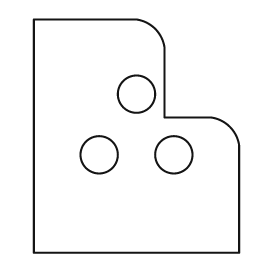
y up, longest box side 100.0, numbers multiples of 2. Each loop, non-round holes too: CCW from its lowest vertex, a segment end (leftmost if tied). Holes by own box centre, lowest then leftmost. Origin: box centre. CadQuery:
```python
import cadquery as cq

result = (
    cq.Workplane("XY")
    .moveTo(-44.0, -50.0)
    .lineTo(44.0, -50.0)
    .lineTo(44.0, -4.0)
    .threePointArc((40.0, 4.0), (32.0, 8.0))
    .lineTo(12.0, 8.0)
    .lineTo(12.0, 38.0)
    .threePointArc((8.0, 46.0), (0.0, 50.0))
    .lineTo(-44.0, 50.0)
    .close()
    .moveTo(-16.0, -8.0)
    .circle(8.0)
    .moveTo(16.0, -8.0)
    .circle(8.0)
    .moveTo(0.0, 18.0)
    .circle(8.0)
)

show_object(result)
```